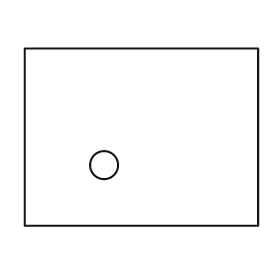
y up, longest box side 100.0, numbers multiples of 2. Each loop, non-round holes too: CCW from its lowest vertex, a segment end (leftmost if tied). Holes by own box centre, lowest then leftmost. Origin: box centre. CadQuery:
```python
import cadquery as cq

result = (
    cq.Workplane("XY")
    .moveTo(-50.0, -38.0)
    .lineTo(50.0, -38.0)
    .lineTo(50.0, 38.0)
    .lineTo(-50.0, 38.0)
    .close()
    .moveTo(-16.0, -12.0)
    .circle(6.0)
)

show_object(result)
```